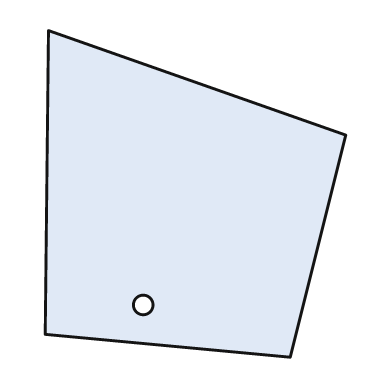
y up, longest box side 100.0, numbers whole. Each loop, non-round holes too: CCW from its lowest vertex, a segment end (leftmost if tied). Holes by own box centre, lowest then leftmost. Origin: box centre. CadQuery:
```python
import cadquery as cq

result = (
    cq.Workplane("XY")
    .moveTo(29.0, -50.0)
    .lineTo(46.0, 18.0)
    .lineTo(-45.0, 50.0)
    .lineTo(-46.0, -43.0)
    .close()
    .moveTo(-16.0, -34.0)
    .circle(3.0)
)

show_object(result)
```